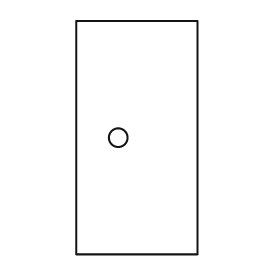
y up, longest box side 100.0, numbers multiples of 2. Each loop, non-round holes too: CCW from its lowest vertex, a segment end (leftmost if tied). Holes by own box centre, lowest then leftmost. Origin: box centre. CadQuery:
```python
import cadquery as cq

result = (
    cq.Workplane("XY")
    .moveTo(-26.0, -50.0)
    .lineTo(26.0, -50.0)
    .lineTo(26.0, 50.0)
    .lineTo(-26.0, 50.0)
    .close()
    .moveTo(-8.0, 0.0)
    .circle(4.0)
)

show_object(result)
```